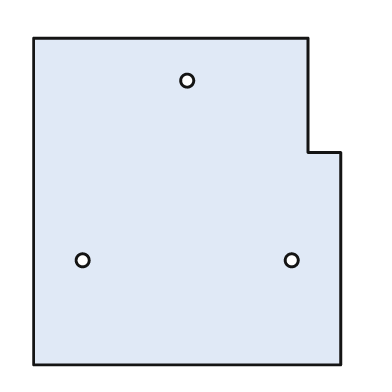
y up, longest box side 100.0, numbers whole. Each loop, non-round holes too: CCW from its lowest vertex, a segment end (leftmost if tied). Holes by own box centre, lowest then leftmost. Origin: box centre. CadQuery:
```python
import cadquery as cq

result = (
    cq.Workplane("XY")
    .moveTo(-47.0, -50.0)
    .lineTo(47.0, -50.0)
    .lineTo(47.0, 15.0)
    .lineTo(37.0, 15.0)
    .lineTo(37.0, 50.0)
    .lineTo(-47.0, 50.0)
    .close()
    .moveTo(-32.0, -18.0)
    .circle(2.0)
    .moveTo(32.0, -18.0)
    .circle(2.0)
    .moveTo(0.0, 37.0)
    .circle(2.0)
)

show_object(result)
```